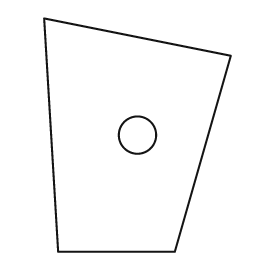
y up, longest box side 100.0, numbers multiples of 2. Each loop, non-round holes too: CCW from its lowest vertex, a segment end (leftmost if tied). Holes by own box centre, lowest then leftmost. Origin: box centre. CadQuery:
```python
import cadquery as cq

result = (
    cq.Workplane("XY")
    .moveTo(-34.0, -50.0)
    .lineTo(16.0, -50.0)
    .lineTo(40.0, 34.0)
    .lineTo(-40.0, 50.0)
    .close()
    .moveTo(0.0, 0.0)
    .circle(8.0)
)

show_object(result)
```